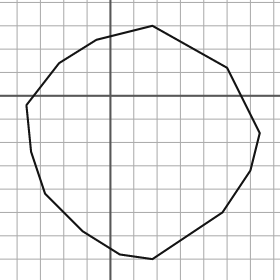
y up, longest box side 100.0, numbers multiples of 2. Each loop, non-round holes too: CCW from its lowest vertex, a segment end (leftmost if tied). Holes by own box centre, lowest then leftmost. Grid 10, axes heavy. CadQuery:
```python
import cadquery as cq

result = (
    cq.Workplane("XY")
    .moveTo(18.0, -70.0)
    .lineTo(48.0, -50.0)
    .lineTo(60.0, -32.0)
    .lineTo(64.0, -16.0)
    .lineTo(50.0, 12.0)
    .lineTo(18.0, 30.0)
    .lineTo(-6.0, 24.0)
    .lineTo(-22.0, 14.0)
    .lineTo(-36.0, -4.0)
    .lineTo(-34.0, -24.0)
    .lineTo(-28.0, -42.0)
    .lineTo(-12.0, -58.0)
    .lineTo(4.0, -68.0)
    .close()
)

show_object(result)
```